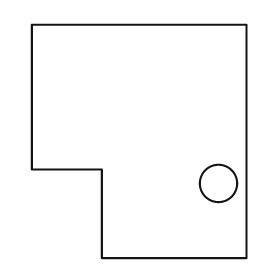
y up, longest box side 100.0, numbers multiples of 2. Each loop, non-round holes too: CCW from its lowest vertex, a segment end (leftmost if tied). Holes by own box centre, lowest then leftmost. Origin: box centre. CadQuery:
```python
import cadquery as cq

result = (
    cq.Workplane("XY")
    .moveTo(-16.0, -50.0)
    .lineTo(46.0, -50.0)
    .lineTo(46.0, 50.0)
    .lineTo(-46.0, 50.0)
    .lineTo(-46.0, -12.0)
    .lineTo(-16.0, -12.0)
    .close()
    .moveTo(34.0, -18.0)
    .circle(8.0)
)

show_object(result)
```